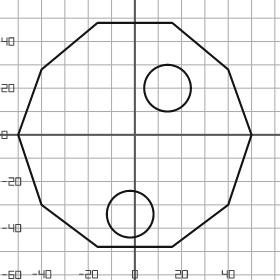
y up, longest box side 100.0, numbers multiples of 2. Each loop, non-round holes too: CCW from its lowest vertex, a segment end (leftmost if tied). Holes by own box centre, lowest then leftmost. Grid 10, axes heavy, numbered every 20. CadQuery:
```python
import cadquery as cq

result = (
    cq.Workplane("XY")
    .moveTo(-16.0, -48.0)
    .lineTo(16.0, -48.0)
    .lineTo(40.0, -30.0)
    .lineTo(50.0, 0.0)
    .lineTo(40.0, 28.0)
    .lineTo(16.0, 48.0)
    .lineTo(-16.0, 48.0)
    .lineTo(-40.0, 28.0)
    .lineTo(-50.0, 0.0)
    .lineTo(-40.0, -30.0)
    .close()
    .moveTo(-2.0, -34.0)
    .circle(10.0)
    .moveTo(14.0, 20.0)
    .circle(10.0)
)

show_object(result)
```